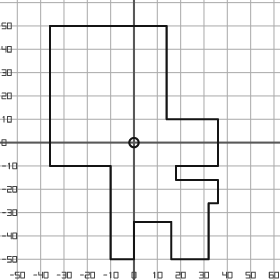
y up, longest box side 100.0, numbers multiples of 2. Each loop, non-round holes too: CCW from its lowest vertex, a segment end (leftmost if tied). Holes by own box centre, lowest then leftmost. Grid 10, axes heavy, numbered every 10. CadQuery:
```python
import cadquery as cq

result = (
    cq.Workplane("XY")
    .moveTo(-10.0, -50.0)
    .lineTo(0.0, -50.0)
    .lineTo(0.0, -34.0)
    .lineTo(16.0, -34.0)
    .lineTo(16.0, -50.0)
    .lineTo(32.0, -50.0)
    .lineTo(32.0, -26.0)
    .lineTo(36.0, -26.0)
    .lineTo(36.0, -16.0)
    .lineTo(18.0, -16.0)
    .lineTo(18.0, -10.0)
    .lineTo(36.0, -10.0)
    .lineTo(36.0, 10.0)
    .lineTo(14.0, 10.0)
    .lineTo(14.0, 50.0)
    .lineTo(-36.0, 50.0)
    .lineTo(-36.0, -10.0)
    .lineTo(-10.0, -10.0)
    .close()
    .moveTo(0.0, 0.0)
    .circle(2.0)
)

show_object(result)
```